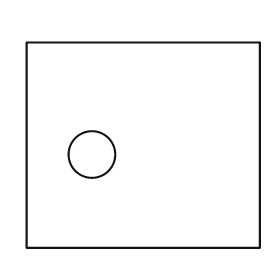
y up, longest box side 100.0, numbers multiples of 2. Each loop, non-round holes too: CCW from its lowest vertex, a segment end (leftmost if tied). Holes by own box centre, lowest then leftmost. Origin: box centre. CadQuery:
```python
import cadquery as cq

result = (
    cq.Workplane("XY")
    .moveTo(-50.0, -44.0)
    .lineTo(50.0, -44.0)
    .lineTo(50.0, 44.0)
    .lineTo(-50.0, 44.0)
    .close()
    .moveTo(-22.0, -4.0)
    .circle(10.0)
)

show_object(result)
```